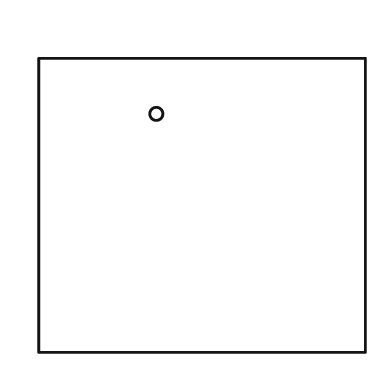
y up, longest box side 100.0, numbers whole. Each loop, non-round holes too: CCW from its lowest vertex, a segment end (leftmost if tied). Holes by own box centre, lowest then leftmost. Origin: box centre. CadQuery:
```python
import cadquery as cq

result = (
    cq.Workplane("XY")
    .moveTo(-50.0, -45.0)
    .lineTo(50.0, -45.0)
    .lineTo(50.0, 45.0)
    .lineTo(-50.0, 45.0)
    .close()
    .moveTo(-14.0, 28.0)
    .circle(2.0)
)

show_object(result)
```